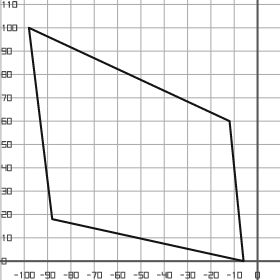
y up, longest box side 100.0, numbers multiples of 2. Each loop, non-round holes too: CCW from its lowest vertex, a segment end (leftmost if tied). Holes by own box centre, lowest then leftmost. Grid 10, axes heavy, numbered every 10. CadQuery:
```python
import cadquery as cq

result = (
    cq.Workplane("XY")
    .moveTo(-6.0, 0.0)
    .lineTo(-12.0, 60.0)
    .lineTo(-98.0, 100.0)
    .lineTo(-88.0, 18.0)
    .close()
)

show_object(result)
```